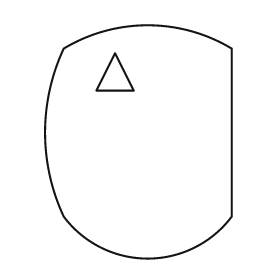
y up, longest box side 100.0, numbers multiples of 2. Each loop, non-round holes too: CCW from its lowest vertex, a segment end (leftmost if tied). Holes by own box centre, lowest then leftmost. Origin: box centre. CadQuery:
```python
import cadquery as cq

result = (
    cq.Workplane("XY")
    .moveTo(-32.0, -32.0)
    .threePointArc((4.0, -50.0), (40.0, -32.0))
    .lineTo(40.0, 40.0)
    .threePointArc((4.0, 50.0), (-32.0, 40.0))
    .threePointArc((-40.0, 4.0), (-32.0, -32.0))
    .close()
    .moveTo(-18.0, 22.0)
    .lineTo(-2.0, 22.0)
    .lineTo(-10.0, 38.0)
    .close()
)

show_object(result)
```